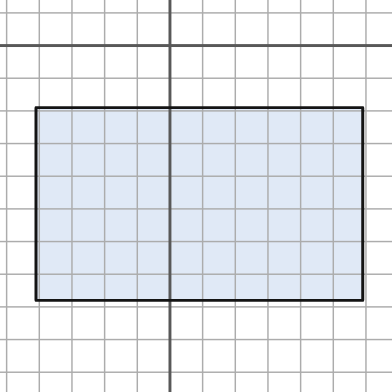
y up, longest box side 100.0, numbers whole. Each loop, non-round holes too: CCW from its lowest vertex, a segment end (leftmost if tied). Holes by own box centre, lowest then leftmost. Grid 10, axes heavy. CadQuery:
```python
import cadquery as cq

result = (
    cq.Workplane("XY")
    .moveTo(-41.0, -78.0)
    .lineTo(59.0, -78.0)
    .lineTo(59.0, -19.0)
    .lineTo(-41.0, -19.0)
    .close()
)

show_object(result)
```